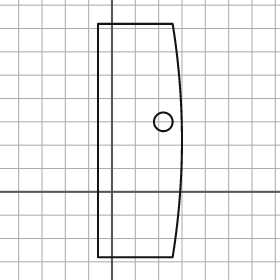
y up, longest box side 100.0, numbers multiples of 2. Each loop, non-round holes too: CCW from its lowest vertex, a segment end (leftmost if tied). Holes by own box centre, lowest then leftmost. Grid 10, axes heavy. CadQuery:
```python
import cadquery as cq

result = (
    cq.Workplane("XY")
    .moveTo(-6.0, -28.0)
    .lineTo(26.0, -28.0)
    .threePointArc((30.0, 22.0), (26.0, 72.0))
    .lineTo(-6.0, 72.0)
    .close()
    .moveTo(22.0, 30.0)
    .circle(4.0)
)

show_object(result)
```